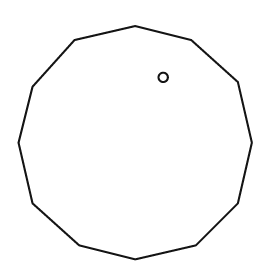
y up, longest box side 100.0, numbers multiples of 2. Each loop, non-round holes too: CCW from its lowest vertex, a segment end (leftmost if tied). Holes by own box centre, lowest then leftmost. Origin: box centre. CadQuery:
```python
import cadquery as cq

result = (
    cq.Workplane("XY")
    .moveTo(0.0, -50.0)
    .lineTo(26.0, -44.0)
    .lineTo(44.0, -26.0)
    .lineTo(50.0, 0.0)
    .lineTo(44.0, 26.0)
    .lineTo(24.0, 44.0)
    .lineTo(0.0, 50.0)
    .lineTo(-26.0, 44.0)
    .lineTo(-44.0, 24.0)
    .lineTo(-50.0, 0.0)
    .lineTo(-44.0, -26.0)
    .lineTo(-24.0, -44.0)
    .close()
    .moveTo(12.0, 28.0)
    .circle(2.0)
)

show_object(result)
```